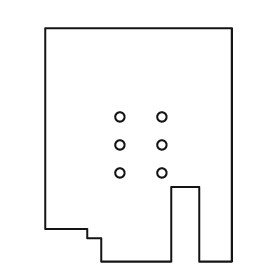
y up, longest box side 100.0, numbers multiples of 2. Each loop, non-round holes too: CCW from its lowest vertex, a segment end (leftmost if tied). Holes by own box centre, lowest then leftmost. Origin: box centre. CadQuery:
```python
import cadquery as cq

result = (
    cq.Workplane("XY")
    .moveTo(-16.0, -50.0)
    .lineTo(14.0, -50.0)
    .lineTo(14.0, -18.0)
    .lineTo(26.0, -18.0)
    .lineTo(26.0, -50.0)
    .lineTo(40.0, -50.0)
    .lineTo(40.0, 50.0)
    .lineTo(-40.0, 50.0)
    .lineTo(-40.0, -36.0)
    .lineTo(-22.0, -36.0)
    .lineTo(-22.0, -40.0)
    .lineTo(-16.0, -40.0)
    .close()
    .moveTo(-8.0, -12.0)
    .circle(2.0)
    .moveTo(10.0, -12.0)
    .circle(2.0)
    .moveTo(-8.0, 0.0)
    .circle(2.0)
    .moveTo(10.0, 0.0)
    .circle(2.0)
    .moveTo(-8.0, 12.0)
    .circle(2.0)
    .moveTo(10.0, 12.0)
    .circle(2.0)
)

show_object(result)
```